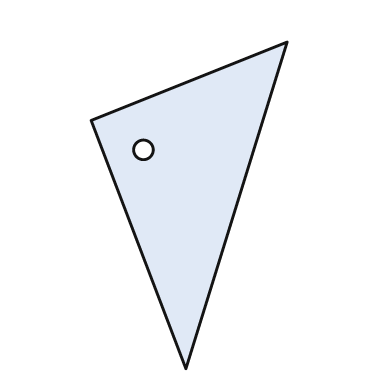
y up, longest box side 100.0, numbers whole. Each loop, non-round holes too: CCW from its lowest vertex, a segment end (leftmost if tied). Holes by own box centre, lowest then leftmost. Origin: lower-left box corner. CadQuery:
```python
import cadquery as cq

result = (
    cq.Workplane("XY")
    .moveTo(29.0, 0.0)
    .lineTo(60.0, 100.0)
    .lineTo(0.0, 76.0)
    .close()
    .moveTo(16.0, 67.0)
    .circle(3.0)
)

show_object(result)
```